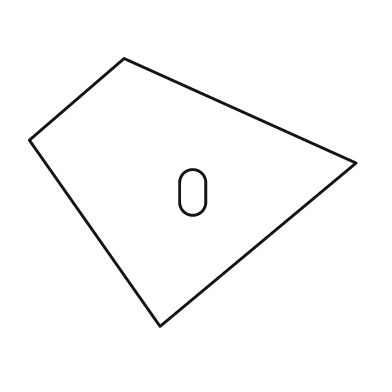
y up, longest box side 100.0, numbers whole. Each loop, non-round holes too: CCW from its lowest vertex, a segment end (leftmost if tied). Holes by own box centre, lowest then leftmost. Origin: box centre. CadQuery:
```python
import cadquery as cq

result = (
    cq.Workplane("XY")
    .moveTo(-10.0, -41.0)
    .lineTo(50.0, 9.0)
    .lineTo(-21.0, 41.0)
    .lineTo(-50.0, 16.0)
    .close()
    .moveTo(-4.0, -3.0)
    .threePointArc((0.0, -7.0), (4.0, -3.0))
    .lineTo(4.0, 3.0)
    .threePointArc((0.0, 7.0), (-4.0, 3.0))
    .close()
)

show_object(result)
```